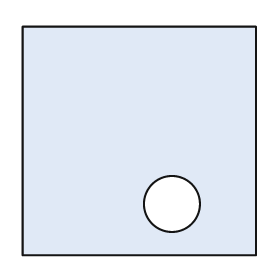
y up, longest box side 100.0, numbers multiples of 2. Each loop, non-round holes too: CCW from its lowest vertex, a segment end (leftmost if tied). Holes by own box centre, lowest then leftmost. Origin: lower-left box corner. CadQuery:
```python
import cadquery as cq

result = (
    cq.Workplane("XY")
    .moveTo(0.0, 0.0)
    .lineTo(100.0, 0.0)
    .lineTo(100.0, 98.0)
    .lineTo(0.0, 98.0)
    .close()
    .moveTo(64.0, 22.0)
    .circle(12.0)
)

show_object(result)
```